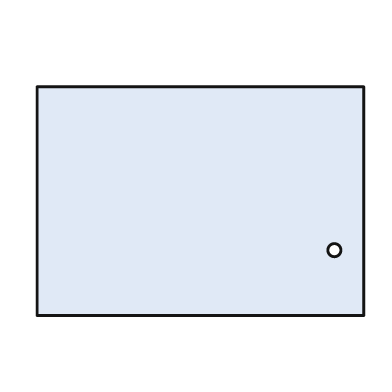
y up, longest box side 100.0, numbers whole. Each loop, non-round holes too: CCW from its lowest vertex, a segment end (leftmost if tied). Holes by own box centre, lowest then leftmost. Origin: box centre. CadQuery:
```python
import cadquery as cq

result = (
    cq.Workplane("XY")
    .moveTo(-50.0, -35.0)
    .lineTo(50.0, -35.0)
    .lineTo(50.0, 35.0)
    .lineTo(-50.0, 35.0)
    .close()
    .moveTo(41.0, -15.0)
    .circle(2.0)
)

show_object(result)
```